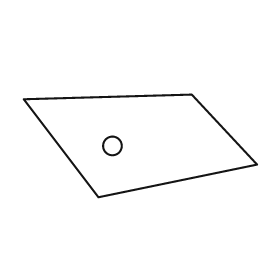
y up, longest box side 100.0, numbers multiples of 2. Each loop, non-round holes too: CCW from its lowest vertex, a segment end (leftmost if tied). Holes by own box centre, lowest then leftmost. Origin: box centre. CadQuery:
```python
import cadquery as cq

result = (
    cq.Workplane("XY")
    .moveTo(-18.0, -22.0)
    .lineTo(50.0, -8.0)
    .lineTo(22.0, 22.0)
    .lineTo(-50.0, 20.0)
    .close()
    .moveTo(-12.0, 0.0)
    .circle(4.0)
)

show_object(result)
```